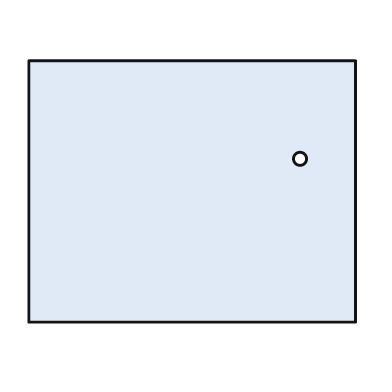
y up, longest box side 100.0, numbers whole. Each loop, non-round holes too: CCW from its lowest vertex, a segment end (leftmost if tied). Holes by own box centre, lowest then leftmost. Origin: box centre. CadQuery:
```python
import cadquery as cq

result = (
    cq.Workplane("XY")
    .moveTo(-50.0, -40.0)
    .lineTo(50.0, -40.0)
    .lineTo(50.0, 40.0)
    .lineTo(-50.0, 40.0)
    .close()
    .moveTo(33.0, 10.0)
    .circle(2.0)
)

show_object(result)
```